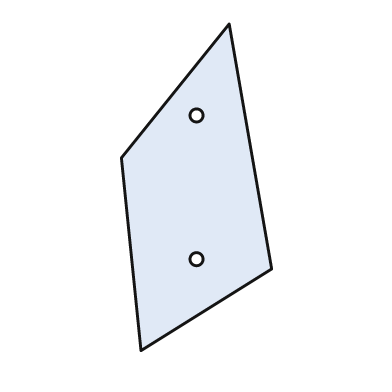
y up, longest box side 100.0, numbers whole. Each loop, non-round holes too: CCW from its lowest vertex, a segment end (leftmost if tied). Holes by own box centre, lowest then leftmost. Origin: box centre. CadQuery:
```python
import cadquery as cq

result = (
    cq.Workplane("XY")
    .moveTo(-17.0, -50.0)
    .lineTo(23.0, -25.0)
    .lineTo(10.0, 50.0)
    .lineTo(-23.0, 9.0)
    .close()
    .moveTo(0.0, -22.0)
    .circle(2.0)
    .moveTo(0.0, 22.0)
    .circle(2.0)
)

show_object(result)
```